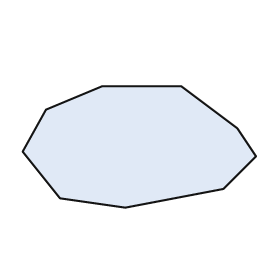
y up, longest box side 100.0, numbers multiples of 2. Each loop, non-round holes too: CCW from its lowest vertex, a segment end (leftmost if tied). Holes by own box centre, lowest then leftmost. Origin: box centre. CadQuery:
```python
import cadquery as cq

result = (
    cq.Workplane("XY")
    .moveTo(-6.0, -26.0)
    .lineTo(36.0, -18.0)
    .lineTo(50.0, -4.0)
    .lineTo(42.0, 8.0)
    .lineTo(18.0, 26.0)
    .lineTo(-16.0, 26.0)
    .lineTo(-40.0, 16.0)
    .lineTo(-50.0, -2.0)
    .lineTo(-34.0, -22.0)
    .close()
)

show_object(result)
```